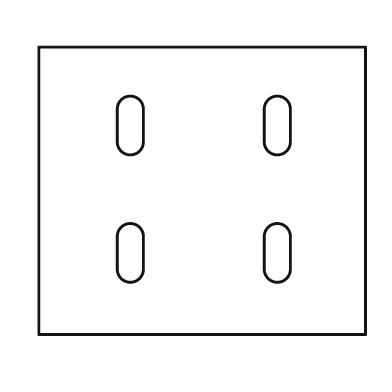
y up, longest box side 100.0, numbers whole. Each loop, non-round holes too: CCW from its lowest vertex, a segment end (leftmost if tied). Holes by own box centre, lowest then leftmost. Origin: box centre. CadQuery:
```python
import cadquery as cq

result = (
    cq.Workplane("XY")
    .moveTo(-50.0, -44.0)
    .lineTo(50.0, -44.0)
    .lineTo(50.0, 44.0)
    .lineTo(-50.0, 44.0)
    .close()
    .moveTo(-26.0, -24.0)
    .threePointArc((-22.0, -28.0), (-18.0, -24.0))
    .lineTo(-18.0, -14.0)
    .threePointArc((-22.0, -10.0), (-26.0, -14.0))
    .close()
    .moveTo(19.0, -24.0)
    .threePointArc((23.0, -28.0), (27.0, -24.0))
    .lineTo(27.0, -14.0)
    .threePointArc((23.0, -10.0), (19.0, -14.0))
    .close()
    .moveTo(-26.0, 15.0)
    .threePointArc((-22.0, 11.0), (-18.0, 15.0))
    .lineTo(-18.0, 25.0)
    .threePointArc((-22.0, 29.0), (-26.0, 25.0))
    .close()
    .moveTo(19.0, 15.0)
    .threePointArc((23.0, 11.0), (27.0, 15.0))
    .lineTo(27.0, 25.0)
    .threePointArc((23.0, 29.0), (19.0, 25.0))
    .close()
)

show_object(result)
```